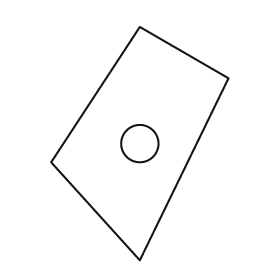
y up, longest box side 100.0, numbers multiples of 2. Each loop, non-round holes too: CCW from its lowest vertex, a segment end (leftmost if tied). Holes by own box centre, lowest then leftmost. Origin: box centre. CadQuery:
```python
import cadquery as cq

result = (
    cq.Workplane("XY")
    .moveTo(0.0, -50.0)
    .lineTo(38.0, 28.0)
    .lineTo(0.0, 50.0)
    .lineTo(-38.0, -8.0)
    .close()
    .moveTo(0.0, 0.0)
    .circle(8.0)
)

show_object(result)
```